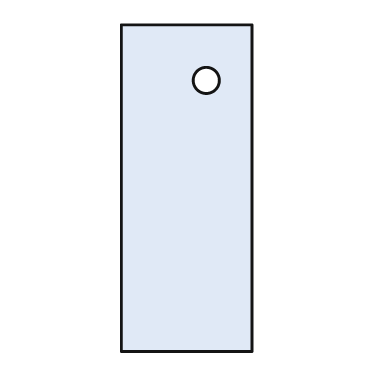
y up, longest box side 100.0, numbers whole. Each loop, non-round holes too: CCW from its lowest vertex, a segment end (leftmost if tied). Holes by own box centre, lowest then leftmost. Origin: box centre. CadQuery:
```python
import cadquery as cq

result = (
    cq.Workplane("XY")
    .moveTo(-20.0, -50.0)
    .lineTo(20.0, -50.0)
    .lineTo(20.0, 50.0)
    .lineTo(-20.0, 50.0)
    .close()
    .moveTo(6.0, 33.0)
    .circle(4.0)
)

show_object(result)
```